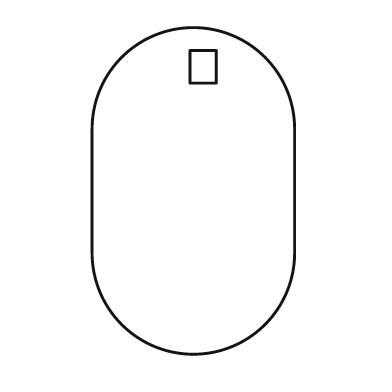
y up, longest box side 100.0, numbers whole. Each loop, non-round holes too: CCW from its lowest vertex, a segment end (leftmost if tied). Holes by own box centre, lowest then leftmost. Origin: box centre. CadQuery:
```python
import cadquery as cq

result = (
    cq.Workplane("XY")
    .moveTo(-31.0, -19.0)
    .threePointArc((0.0, -50.0), (31.0, -19.0))
    .lineTo(31.0, 19.0)
    .threePointArc((0.0, 50.0), (-31.0, 19.0))
    .close()
    .moveTo(-1.0, 33.0)
    .lineTo(7.0, 33.0)
    .lineTo(7.0, 43.0)
    .lineTo(-1.0, 43.0)
    .close()
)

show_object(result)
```